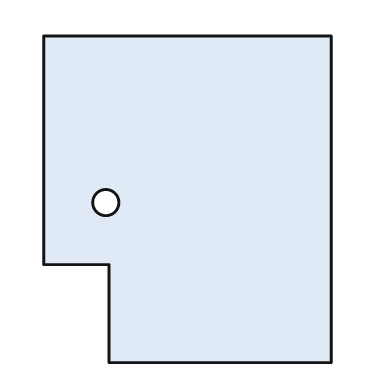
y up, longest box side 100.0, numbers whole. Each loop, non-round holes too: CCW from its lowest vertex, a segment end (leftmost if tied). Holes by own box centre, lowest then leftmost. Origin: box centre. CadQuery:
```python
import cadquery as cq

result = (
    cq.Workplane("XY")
    .moveTo(-24.0, -50.0)
    .lineTo(44.0, -50.0)
    .lineTo(44.0, 50.0)
    .lineTo(-44.0, 50.0)
    .lineTo(-44.0, -20.0)
    .lineTo(-24.0, -20.0)
    .close()
    .moveTo(-25.0, -1.0)
    .circle(4.0)
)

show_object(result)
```